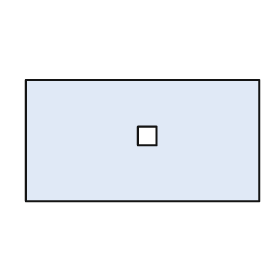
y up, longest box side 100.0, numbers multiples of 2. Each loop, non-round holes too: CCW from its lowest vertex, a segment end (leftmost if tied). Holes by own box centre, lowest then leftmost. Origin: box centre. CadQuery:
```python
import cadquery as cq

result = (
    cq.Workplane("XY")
    .moveTo(-50.0, -26.0)
    .lineTo(50.0, -26.0)
    .lineTo(50.0, 26.0)
    .lineTo(-50.0, 26.0)
    .close()
    .moveTo(-2.0, -2.0)
    .lineTo(6.0, -2.0)
    .lineTo(6.0, 6.0)
    .lineTo(-2.0, 6.0)
    .close()
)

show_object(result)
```